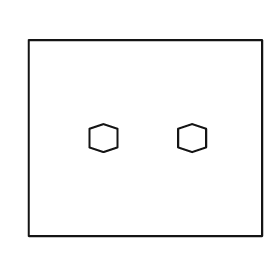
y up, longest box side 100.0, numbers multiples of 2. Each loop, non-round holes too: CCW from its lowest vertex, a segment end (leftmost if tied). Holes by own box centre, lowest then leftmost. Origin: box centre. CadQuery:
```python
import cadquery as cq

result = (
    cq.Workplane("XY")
    .moveTo(-50.0, -42.0)
    .lineTo(50.0, -42.0)
    .lineTo(50.0, 42.0)
    .lineTo(-50.0, 42.0)
    .close()
    .moveTo(-18.0, -6.0)
    .lineTo(-12.0, -4.0)
    .lineTo(-12.0, 4.0)
    .lineTo(-18.0, 6.0)
    .lineTo(-24.0, 4.0)
    .lineTo(-24.0, -4.0)
    .close()
    .moveTo(20.0, -6.0)
    .lineTo(26.0, -4.0)
    .lineTo(26.0, 4.0)
    .lineTo(20.0, 6.0)
    .lineTo(14.0, 4.0)
    .lineTo(14.0, -4.0)
    .close()
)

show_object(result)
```